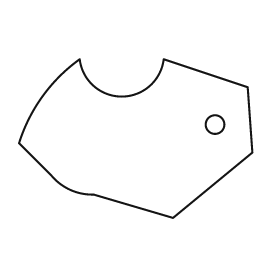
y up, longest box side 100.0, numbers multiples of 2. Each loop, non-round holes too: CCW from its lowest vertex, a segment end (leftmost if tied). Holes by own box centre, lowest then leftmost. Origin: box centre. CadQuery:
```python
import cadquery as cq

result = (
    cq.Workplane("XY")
    .moveTo(16.0, -34.0)
    .lineTo(50.0, -6.0)
    .lineTo(48.0, 22.0)
    .lineTo(12.0, 34.0)
    .threePointArc((-6.0, 18.0), (-24.0, 34.0))
    .threePointArc((-40.0, 18.0), (-50.0, -2.0))
    .lineTo(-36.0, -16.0)
    .threePointArc((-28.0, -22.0), (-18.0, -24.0))
    .close()
    .moveTo(34.0, 6.0)
    .circle(4.0)
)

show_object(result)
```